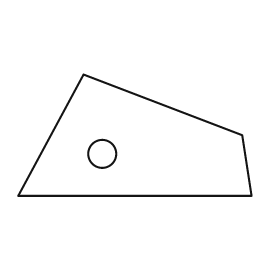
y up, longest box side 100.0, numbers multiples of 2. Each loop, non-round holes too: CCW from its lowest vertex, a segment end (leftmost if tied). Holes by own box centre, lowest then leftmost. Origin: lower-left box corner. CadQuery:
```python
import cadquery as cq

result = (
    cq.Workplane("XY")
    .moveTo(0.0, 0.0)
    .lineTo(100.0, 0.0)
    .lineTo(96.0, 26.0)
    .lineTo(28.0, 52.0)
    .close()
    .moveTo(36.0, 18.0)
    .circle(6.0)
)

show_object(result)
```